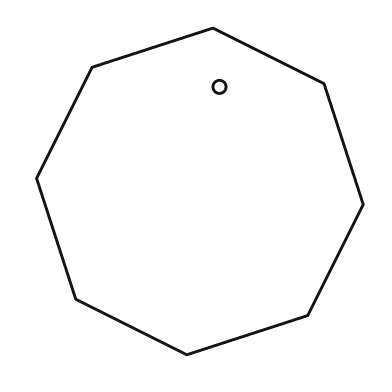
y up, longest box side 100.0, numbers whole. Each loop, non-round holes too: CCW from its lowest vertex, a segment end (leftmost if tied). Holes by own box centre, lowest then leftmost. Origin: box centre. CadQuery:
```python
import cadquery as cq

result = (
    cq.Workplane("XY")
    .moveTo(-4.0, -50.0)
    .lineTo(33.0, -38.0)
    .lineTo(50.0, -4.0)
    .lineTo(38.0, 33.0)
    .lineTo(4.0, 50.0)
    .lineTo(-33.0, 38.0)
    .lineTo(-50.0, 4.0)
    .lineTo(-38.0, -33.0)
    .close()
    .moveTo(6.0, 32.0)
    .circle(2.0)
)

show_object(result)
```